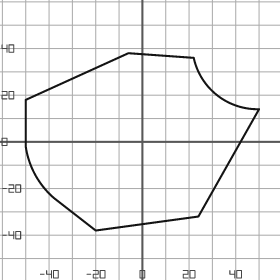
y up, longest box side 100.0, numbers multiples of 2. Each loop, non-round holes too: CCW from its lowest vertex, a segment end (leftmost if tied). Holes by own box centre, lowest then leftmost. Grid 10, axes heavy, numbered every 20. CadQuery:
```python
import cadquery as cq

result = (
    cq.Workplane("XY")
    .moveTo(-20.0, -38.0)
    .lineTo(24.0, -32.0)
    .lineTo(50.0, 14.0)
    .threePointArc((32.0, 20.0), (22.0, 36.0))
    .lineTo(-6.0, 38.0)
    .lineTo(-50.0, 18.0)
    .lineTo(-50.0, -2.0)
    .threePointArc((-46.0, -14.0), (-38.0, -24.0))
    .close()
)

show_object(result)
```